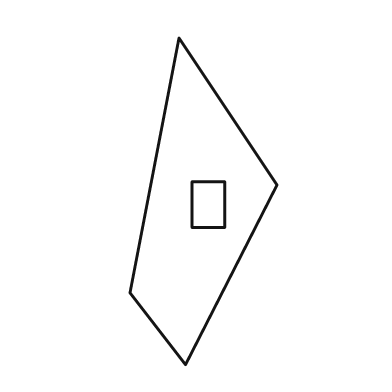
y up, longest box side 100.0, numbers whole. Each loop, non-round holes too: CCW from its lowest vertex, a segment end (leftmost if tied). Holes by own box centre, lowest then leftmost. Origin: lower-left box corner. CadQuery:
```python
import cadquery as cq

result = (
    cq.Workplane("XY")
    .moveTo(17.0, 0.0)
    .lineTo(45.0, 55.0)
    .lineTo(15.0, 100.0)
    .lineTo(0.0, 22.0)
    .close()
    .moveTo(19.0, 42.0)
    .lineTo(29.0, 42.0)
    .lineTo(29.0, 56.0)
    .lineTo(19.0, 56.0)
    .close()
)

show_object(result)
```